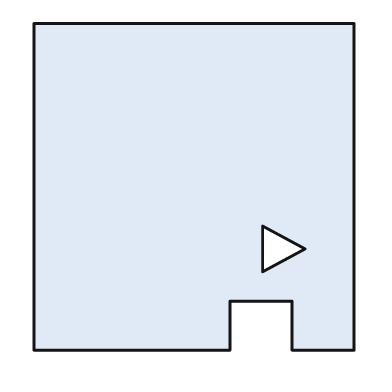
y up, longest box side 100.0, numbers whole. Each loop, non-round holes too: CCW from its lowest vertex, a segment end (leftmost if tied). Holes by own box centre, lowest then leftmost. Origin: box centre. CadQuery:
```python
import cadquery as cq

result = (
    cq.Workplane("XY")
    .moveTo(-49.0, -50.0)
    .lineTo(11.0, -50.0)
    .lineTo(11.0, -35.0)
    .lineTo(30.0, -35.0)
    .lineTo(30.0, -50.0)
    .lineTo(49.0, -50.0)
    .lineTo(49.0, 50.0)
    .lineTo(-49.0, 50.0)
    .close()
    .moveTo(21.0, -26.0)
    .lineTo(34.0, -19.0)
    .lineTo(21.0, -12.0)
    .close()
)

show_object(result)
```